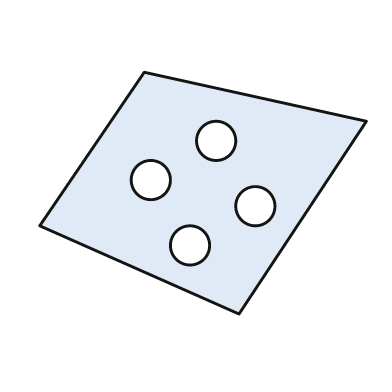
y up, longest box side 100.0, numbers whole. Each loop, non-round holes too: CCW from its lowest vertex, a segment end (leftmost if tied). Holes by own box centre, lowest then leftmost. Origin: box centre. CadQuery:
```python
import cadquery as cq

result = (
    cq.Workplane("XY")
    .moveTo(11.0, -37.0)
    .lineTo(50.0, 22.0)
    .lineTo(-18.0, 37.0)
    .lineTo(-50.0, -10.0)
    .close()
    .moveTo(-4.0, -16.0)
    .circle(6.0)
    .moveTo(16.0, -4.0)
    .circle(6.0)
    .moveTo(-16.0, 4.0)
    .circle(6.0)
    .moveTo(4.0, 16.0)
    .circle(6.0)
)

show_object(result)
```